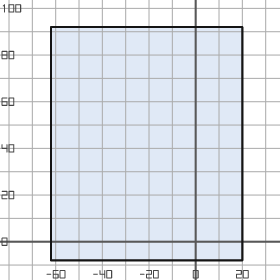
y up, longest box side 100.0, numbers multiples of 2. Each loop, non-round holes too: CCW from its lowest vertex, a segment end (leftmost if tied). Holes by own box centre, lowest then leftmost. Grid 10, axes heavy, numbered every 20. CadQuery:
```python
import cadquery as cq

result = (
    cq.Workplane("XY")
    .moveTo(-62.0, -8.0)
    .lineTo(20.0, -8.0)
    .lineTo(20.0, 92.0)
    .lineTo(-62.0, 92.0)
    .close()
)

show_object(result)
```